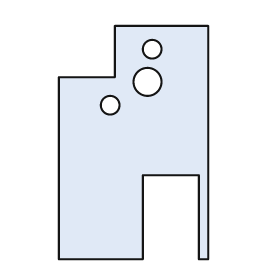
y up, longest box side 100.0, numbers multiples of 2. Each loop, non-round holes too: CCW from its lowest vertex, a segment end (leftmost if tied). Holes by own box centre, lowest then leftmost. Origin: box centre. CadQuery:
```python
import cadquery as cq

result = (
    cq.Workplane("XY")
    .moveTo(-32.0, -50.0)
    .lineTo(4.0, -50.0)
    .lineTo(4.0, -14.0)
    .lineTo(28.0, -14.0)
    .lineTo(28.0, -50.0)
    .lineTo(32.0, -50.0)
    .lineTo(32.0, 50.0)
    .lineTo(-8.0, 50.0)
    .lineTo(-8.0, 28.0)
    .lineTo(-32.0, 28.0)
    .close()
    .moveTo(-10.0, 16.0)
    .circle(4.0)
    .moveTo(6.0, 26.0)
    .circle(6.0)
    .moveTo(8.0, 40.0)
    .circle(4.0)
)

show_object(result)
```